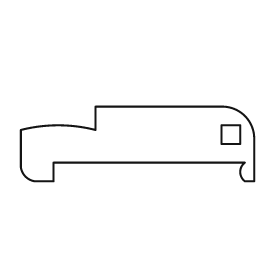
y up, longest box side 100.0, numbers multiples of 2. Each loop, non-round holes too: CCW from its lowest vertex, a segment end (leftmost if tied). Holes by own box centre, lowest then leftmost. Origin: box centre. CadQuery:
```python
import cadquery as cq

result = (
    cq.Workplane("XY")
    .moveTo(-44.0, -16.0)
    .lineTo(-36.0, -16.0)
    .lineTo(-36.0, -8.0)
    .lineTo(46.0, -8.0)
    .threePointArc((44.0, -12.0), (46.0, -16.0))
    .lineTo(50.0, -16.0)
    .lineTo(50.0, 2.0)
    .threePointArc((46.0, 12.0), (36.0, 16.0))
    .lineTo(-18.0, 16.0)
    .lineTo(-18.0, 6.0)
    .threePointArc((-34.0, 8.0), (-50.0, 6.0))
    .lineTo(-50.0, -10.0)
    .threePointArc((-48.0, -14.0), (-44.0, -16.0))
    .close()
    .moveTo(36.0, 0.0)
    .lineTo(44.0, 0.0)
    .lineTo(44.0, 8.0)
    .lineTo(36.0, 8.0)
    .close()
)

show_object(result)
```